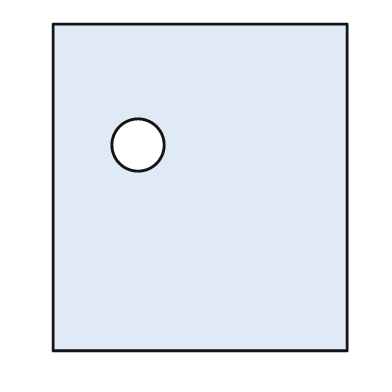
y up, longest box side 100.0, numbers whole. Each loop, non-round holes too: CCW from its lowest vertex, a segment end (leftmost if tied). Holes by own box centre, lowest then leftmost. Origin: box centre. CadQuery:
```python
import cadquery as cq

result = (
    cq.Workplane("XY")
    .moveTo(-45.0, -50.0)
    .lineTo(45.0, -50.0)
    .lineTo(45.0, 50.0)
    .lineTo(-45.0, 50.0)
    .close()
    .moveTo(-19.0, 13.0)
    .circle(8.0)
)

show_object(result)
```